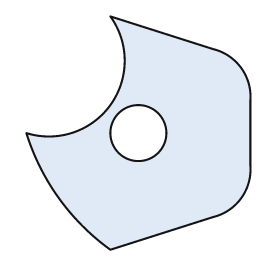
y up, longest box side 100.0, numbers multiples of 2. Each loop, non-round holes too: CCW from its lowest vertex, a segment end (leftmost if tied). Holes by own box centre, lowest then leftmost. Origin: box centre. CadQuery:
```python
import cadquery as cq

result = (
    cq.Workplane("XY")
    .moveTo(-12.0, -50.0)
    .lineTo(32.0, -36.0)
    .threePointArc((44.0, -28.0), (48.0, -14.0))
    .lineTo(48.0, 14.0)
    .threePointArc((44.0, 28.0), (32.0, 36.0))
    .lineTo(-12.0, 50.0)
    .threePointArc((-12.0, 12.0), (-48.0, 0.0))
    .threePointArc((-34.0, -28.0), (-12.0, -50.0))
    .close()
    .moveTo(0.0, 0.0)
    .circle(12.0)
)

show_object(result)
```